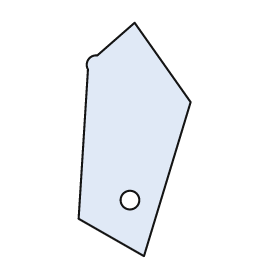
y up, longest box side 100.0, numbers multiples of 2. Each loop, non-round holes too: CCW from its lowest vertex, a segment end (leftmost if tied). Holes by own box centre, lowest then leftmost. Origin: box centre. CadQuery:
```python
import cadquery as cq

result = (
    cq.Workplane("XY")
    .moveTo(4.0, -50.0)
    .lineTo(24.0, 16.0)
    .lineTo(0.0, 50.0)
    .lineTo(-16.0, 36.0)
    .threePointArc((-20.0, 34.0), (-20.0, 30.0))
    .lineTo(-24.0, -34.0)
    .close()
    .moveTo(-2.0, -26.0)
    .circle(4.0)
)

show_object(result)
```